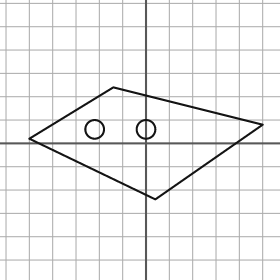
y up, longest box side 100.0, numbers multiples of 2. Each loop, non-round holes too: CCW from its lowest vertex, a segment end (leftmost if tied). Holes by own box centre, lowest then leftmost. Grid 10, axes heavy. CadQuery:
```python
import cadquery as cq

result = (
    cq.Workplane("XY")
    .moveTo(4.0, -24.0)
    .lineTo(50.0, 8.0)
    .lineTo(-14.0, 24.0)
    .lineTo(-50.0, 2.0)
    .close()
    .moveTo(-22.0, 6.0)
    .circle(4.0)
    .moveTo(0.0, 6.0)
    .circle(4.0)
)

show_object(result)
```